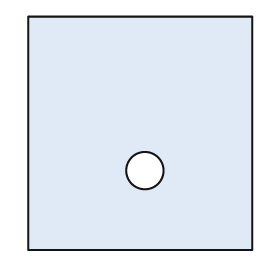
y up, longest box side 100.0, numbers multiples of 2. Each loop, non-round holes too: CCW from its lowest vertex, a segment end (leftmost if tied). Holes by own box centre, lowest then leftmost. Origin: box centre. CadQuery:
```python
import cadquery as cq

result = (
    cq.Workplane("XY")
    .moveTo(-48.0, -50.0)
    .lineTo(48.0, -50.0)
    .lineTo(48.0, 50.0)
    .lineTo(-48.0, 50.0)
    .close()
    .moveTo(2.0, -16.0)
    .circle(8.0)
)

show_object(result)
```